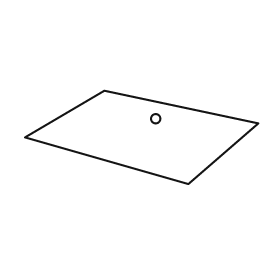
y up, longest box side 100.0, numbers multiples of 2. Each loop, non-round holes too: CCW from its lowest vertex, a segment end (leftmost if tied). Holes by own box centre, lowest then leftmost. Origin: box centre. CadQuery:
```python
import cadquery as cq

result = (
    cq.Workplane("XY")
    .moveTo(20.0, -20.0)
    .lineTo(50.0, 6.0)
    .lineTo(-16.0, 20.0)
    .lineTo(-50.0, 0.0)
    .close()
    .moveTo(6.0, 8.0)
    .circle(2.0)
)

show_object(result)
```